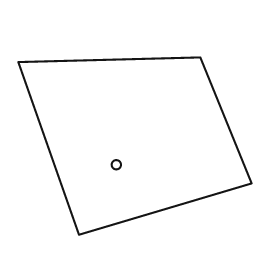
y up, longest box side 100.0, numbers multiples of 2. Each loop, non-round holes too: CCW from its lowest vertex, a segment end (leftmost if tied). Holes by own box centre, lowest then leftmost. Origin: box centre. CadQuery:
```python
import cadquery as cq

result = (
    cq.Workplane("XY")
    .moveTo(-24.0, -38.0)
    .lineTo(50.0, -16.0)
    .lineTo(28.0, 38.0)
    .lineTo(-50.0, 36.0)
    .close()
    .moveTo(-8.0, -8.0)
    .circle(2.0)
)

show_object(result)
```